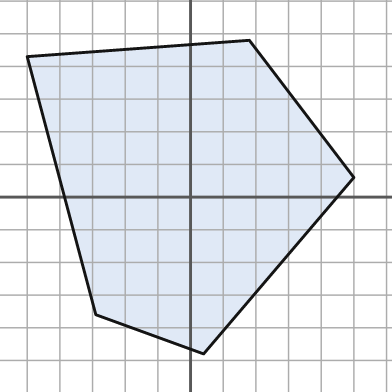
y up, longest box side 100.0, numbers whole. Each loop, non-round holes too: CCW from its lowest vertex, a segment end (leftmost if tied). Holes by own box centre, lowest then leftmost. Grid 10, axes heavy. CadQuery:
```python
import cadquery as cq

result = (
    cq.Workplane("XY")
    .moveTo(4.0, -48.0)
    .lineTo(50.0, 6.0)
    .lineTo(18.0, 48.0)
    .lineTo(-50.0, 43.0)
    .lineTo(-29.0, -36.0)
    .close()
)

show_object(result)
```